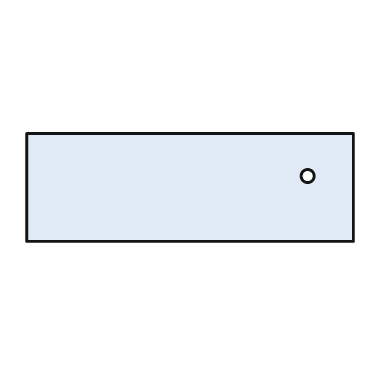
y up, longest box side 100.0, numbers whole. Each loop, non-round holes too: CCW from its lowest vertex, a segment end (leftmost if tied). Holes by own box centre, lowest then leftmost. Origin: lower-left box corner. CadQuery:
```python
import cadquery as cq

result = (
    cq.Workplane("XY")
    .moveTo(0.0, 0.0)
    .lineTo(100.0, 0.0)
    .lineTo(100.0, 33.0)
    .lineTo(0.0, 33.0)
    .close()
    .moveTo(86.0, 20.0)
    .circle(2.0)
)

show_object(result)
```